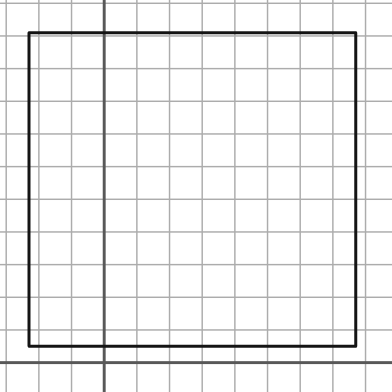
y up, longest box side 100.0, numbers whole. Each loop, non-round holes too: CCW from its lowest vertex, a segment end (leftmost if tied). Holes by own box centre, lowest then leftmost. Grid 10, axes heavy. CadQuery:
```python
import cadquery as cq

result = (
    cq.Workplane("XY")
    .moveTo(-23.0, 5.0)
    .lineTo(77.0, 5.0)
    .lineTo(77.0, 101.0)
    .lineTo(-23.0, 101.0)
    .close()
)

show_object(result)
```